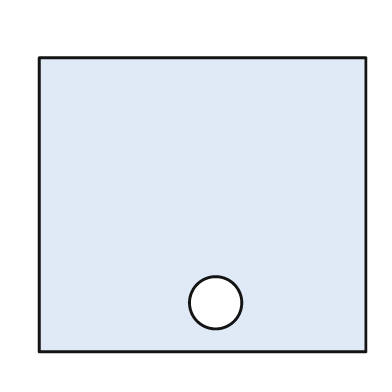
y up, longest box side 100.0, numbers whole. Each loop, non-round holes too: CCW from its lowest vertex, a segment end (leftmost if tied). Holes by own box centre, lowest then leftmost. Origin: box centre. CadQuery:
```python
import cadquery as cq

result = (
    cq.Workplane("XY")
    .moveTo(-50.0, -45.0)
    .lineTo(50.0, -45.0)
    .lineTo(50.0, 45.0)
    .lineTo(-50.0, 45.0)
    .close()
    .moveTo(4.0, -30.0)
    .circle(8.0)
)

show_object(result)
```